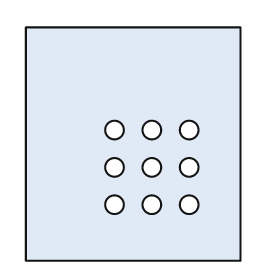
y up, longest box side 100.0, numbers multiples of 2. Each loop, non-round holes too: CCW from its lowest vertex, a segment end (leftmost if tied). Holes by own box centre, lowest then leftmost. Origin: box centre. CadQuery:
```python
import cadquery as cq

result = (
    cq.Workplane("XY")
    .moveTo(-46.0, -50.0)
    .lineTo(46.0, -50.0)
    .lineTo(46.0, 50.0)
    .lineTo(-46.0, 50.0)
    .close()
    .moveTo(-8.0, -26.0)
    .circle(4.0)
    .moveTo(8.0, -26.0)
    .circle(4.0)
    .moveTo(24.0, -26.0)
    .circle(4.0)
    .moveTo(-8.0, -10.0)
    .circle(4.0)
    .moveTo(8.0, -10.0)
    .circle(4.0)
    .moveTo(24.0, -10.0)
    .circle(4.0)
    .moveTo(-8.0, 6.0)
    .circle(4.0)
    .moveTo(8.0, 6.0)
    .circle(4.0)
    .moveTo(24.0, 6.0)
    .circle(4.0)
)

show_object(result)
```